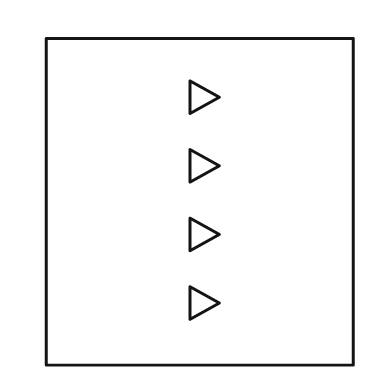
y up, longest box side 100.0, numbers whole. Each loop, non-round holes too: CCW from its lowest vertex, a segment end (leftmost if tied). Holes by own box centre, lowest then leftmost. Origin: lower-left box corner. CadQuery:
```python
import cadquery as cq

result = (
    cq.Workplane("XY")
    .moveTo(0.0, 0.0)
    .lineTo(94.0, 0.0)
    .lineTo(94.0, 100.0)
    .lineTo(0.0, 100.0)
    .close()
    .moveTo(44.0, 14.0)
    .lineTo(53.0, 19.0)
    .lineTo(44.0, 24.0)
    .close()
    .moveTo(44.0, 35.0)
    .lineTo(53.0, 40.0)
    .lineTo(44.0, 45.0)
    .close()
    .moveTo(44.0, 56.0)
    .lineTo(53.0, 61.0)
    .lineTo(44.0, 66.0)
    .close()
    .moveTo(44.0, 77.0)
    .lineTo(53.0, 82.0)
    .lineTo(44.0, 87.0)
    .close()
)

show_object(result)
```